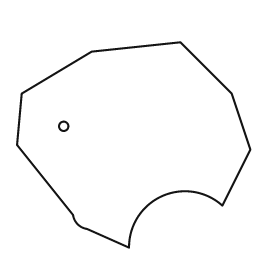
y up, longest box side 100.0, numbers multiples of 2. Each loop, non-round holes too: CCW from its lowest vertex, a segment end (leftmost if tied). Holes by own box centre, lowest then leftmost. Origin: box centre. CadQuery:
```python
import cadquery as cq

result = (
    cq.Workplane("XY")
    .moveTo(-2.0, -44.0)
    .threePointArc((12.0, -22.0), (38.0, -26.0))
    .lineTo(50.0, -2.0)
    .lineTo(42.0, 22.0)
    .lineTo(20.0, 44.0)
    .lineTo(-18.0, 40.0)
    .lineTo(-48.0, 22.0)
    .lineTo(-50.0, 0.0)
    .lineTo(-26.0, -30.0)
    .threePointArc((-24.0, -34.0), (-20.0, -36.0))
    .close()
    .moveTo(-30.0, 8.0)
    .circle(2.0)
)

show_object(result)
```